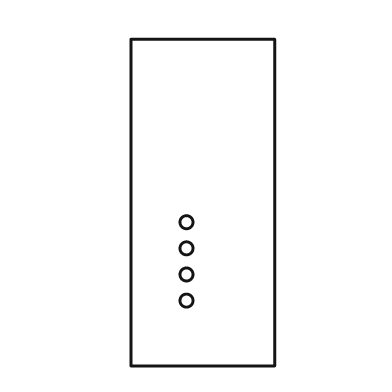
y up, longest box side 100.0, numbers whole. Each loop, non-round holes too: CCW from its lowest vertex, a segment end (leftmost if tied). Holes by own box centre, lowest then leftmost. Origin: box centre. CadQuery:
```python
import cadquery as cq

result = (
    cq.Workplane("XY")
    .moveTo(-22.0, -50.0)
    .lineTo(22.0, -50.0)
    .lineTo(22.0, 50.0)
    .lineTo(-22.0, 50.0)
    .close()
    .moveTo(-5.0, -30.0)
    .circle(2.0)
    .moveTo(-5.0, -22.0)
    .circle(2.0)
    .moveTo(-5.0, -14.0)
    .circle(2.0)
    .moveTo(-5.0, -6.0)
    .circle(2.0)
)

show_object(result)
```